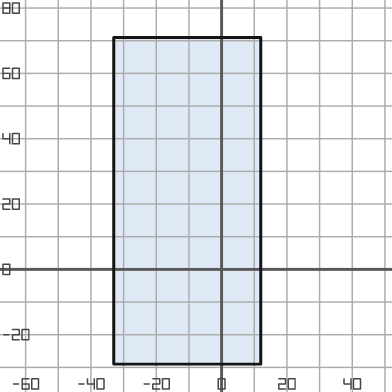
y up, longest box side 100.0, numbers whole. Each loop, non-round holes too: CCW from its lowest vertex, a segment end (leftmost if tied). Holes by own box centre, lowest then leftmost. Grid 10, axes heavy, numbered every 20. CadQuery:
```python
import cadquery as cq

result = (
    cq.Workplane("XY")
    .moveTo(-33.0, -29.0)
    .lineTo(12.0, -29.0)
    .lineTo(12.0, 71.0)
    .lineTo(-33.0, 71.0)
    .close()
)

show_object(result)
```